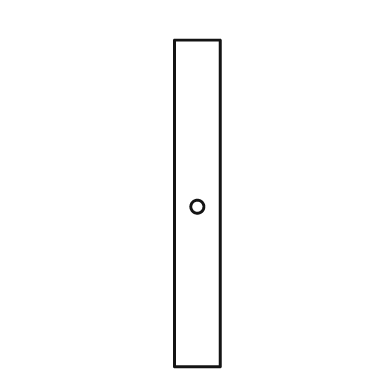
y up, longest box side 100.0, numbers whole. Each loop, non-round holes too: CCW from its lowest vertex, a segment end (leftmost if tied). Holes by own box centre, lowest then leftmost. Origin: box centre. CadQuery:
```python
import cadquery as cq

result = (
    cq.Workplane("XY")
    .moveTo(-7.0, -50.0)
    .lineTo(7.0, -50.0)
    .lineTo(7.0, 50.0)
    .lineTo(-7.0, 50.0)
    .close()
    .moveTo(0.0, -1.0)
    .circle(2.0)
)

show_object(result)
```